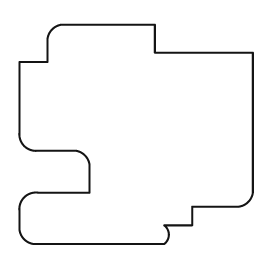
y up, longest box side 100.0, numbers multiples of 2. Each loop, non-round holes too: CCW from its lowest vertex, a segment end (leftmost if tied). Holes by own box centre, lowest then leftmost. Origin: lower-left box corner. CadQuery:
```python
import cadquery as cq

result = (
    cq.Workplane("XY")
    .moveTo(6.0, 0.0)
    .lineTo(62.0, 0.0)
    .threePointArc((64.0, 4.0), (62.0, 8.0))
    .lineTo(74.0, 8.0)
    .lineTo(74.0, 16.0)
    .lineTo(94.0, 16.0)
    .threePointArc((98.0, 18.0), (100.0, 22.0))
    .lineTo(100.0, 82.0)
    .lineTo(58.0, 82.0)
    .lineTo(58.0, 94.0)
    .lineTo(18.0, 94.0)
    .threePointArc((14.0, 92.0), (12.0, 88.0))
    .lineTo(12.0, 78.0)
    .lineTo(0.0, 78.0)
    .lineTo(0.0, 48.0)
    .threePointArc((2.0, 42.0), (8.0, 40.0))
    .lineTo(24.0, 40.0)
    .threePointArc((28.0, 38.0), (30.0, 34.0))
    .lineTo(30.0, 22.0)
    .lineTo(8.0, 22.0)
    .threePointArc((2.0, 20.0), (0.0, 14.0))
    .lineTo(0.0, 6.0)
    .threePointArc((2.0, 2.0), (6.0, 0.0))
    .close()
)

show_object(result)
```